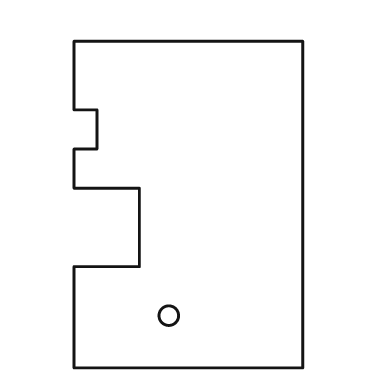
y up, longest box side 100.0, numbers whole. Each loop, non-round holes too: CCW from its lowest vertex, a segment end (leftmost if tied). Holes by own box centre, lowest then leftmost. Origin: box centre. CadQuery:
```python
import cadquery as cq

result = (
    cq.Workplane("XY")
    .moveTo(-35.0, -50.0)
    .lineTo(35.0, -50.0)
    .lineTo(35.0, 50.0)
    .lineTo(-35.0, 50.0)
    .lineTo(-35.0, 29.0)
    .lineTo(-28.0, 29.0)
    .lineTo(-28.0, 17.0)
    .lineTo(-35.0, 17.0)
    .lineTo(-35.0, 5.0)
    .lineTo(-15.0, 5.0)
    .lineTo(-15.0, -19.0)
    .lineTo(-35.0, -19.0)
    .close()
    .moveTo(-6.0, -34.0)
    .circle(3.0)
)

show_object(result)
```